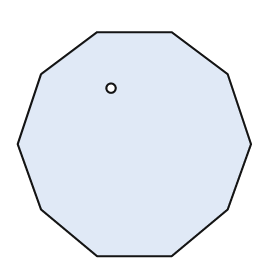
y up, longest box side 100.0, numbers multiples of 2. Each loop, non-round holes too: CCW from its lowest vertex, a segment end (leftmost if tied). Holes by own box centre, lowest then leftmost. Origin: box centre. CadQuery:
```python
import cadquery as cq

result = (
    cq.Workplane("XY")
    .moveTo(-16.0, -48.0)
    .lineTo(16.0, -48.0)
    .lineTo(40.0, -28.0)
    .lineTo(50.0, 0.0)
    .lineTo(40.0, 30.0)
    .lineTo(16.0, 48.0)
    .lineTo(-16.0, 48.0)
    .lineTo(-40.0, 30.0)
    .lineTo(-50.0, 0.0)
    .lineTo(-40.0, -28.0)
    .close()
    .moveTo(-10.0, 24.0)
    .circle(2.0)
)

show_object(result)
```